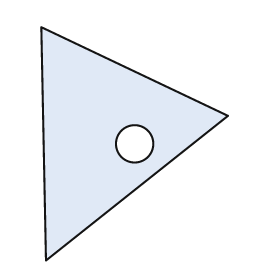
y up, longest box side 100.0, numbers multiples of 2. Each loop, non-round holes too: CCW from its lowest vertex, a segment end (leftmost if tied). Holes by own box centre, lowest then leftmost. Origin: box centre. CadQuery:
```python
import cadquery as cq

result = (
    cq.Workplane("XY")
    .moveTo(-38.0, -50.0)
    .lineTo(40.0, 12.0)
    .lineTo(-40.0, 50.0)
    .close()
    .moveTo(0.0, 0.0)
    .circle(8.0)
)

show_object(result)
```